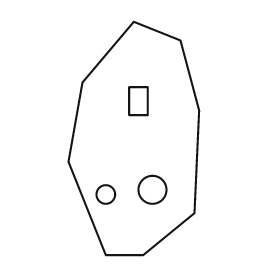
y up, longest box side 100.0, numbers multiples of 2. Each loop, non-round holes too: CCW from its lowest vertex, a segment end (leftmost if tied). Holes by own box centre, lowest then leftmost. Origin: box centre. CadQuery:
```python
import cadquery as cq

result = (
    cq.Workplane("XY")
    .moveTo(-12.0, -50.0)
    .lineTo(4.0, -50.0)
    .lineTo(26.0, -32.0)
    .lineTo(28.0, 12.0)
    .lineTo(20.0, 42.0)
    .lineTo(0.0, 50.0)
    .lineTo(-22.0, 24.0)
    .lineTo(-28.0, -10.0)
    .close()
    .moveTo(-12.0, -24.0)
    .circle(4.0)
    .moveTo(8.0, -22.0)
    .circle(6.0)
    .moveTo(-2.0, 10.0)
    .lineTo(6.0, 10.0)
    .lineTo(6.0, 22.0)
    .lineTo(-2.0, 22.0)
    .close()
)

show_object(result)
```